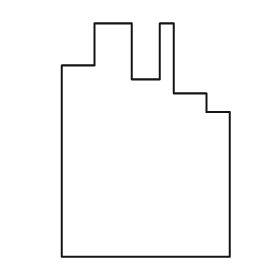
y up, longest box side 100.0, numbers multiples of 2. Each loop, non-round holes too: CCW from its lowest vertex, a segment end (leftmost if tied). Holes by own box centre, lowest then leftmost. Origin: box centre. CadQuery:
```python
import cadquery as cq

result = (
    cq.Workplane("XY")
    .moveTo(-36.0, -50.0)
    .lineTo(36.0, -50.0)
    .lineTo(36.0, 12.0)
    .lineTo(26.0, 12.0)
    .lineTo(26.0, 20.0)
    .lineTo(12.0, 20.0)
    .lineTo(12.0, 50.0)
    .lineTo(6.0, 50.0)
    .lineTo(6.0, 26.0)
    .lineTo(-6.0, 26.0)
    .lineTo(-6.0, 50.0)
    .lineTo(-22.0, 50.0)
    .lineTo(-22.0, 32.0)
    .lineTo(-36.0, 32.0)
    .close()
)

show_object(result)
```